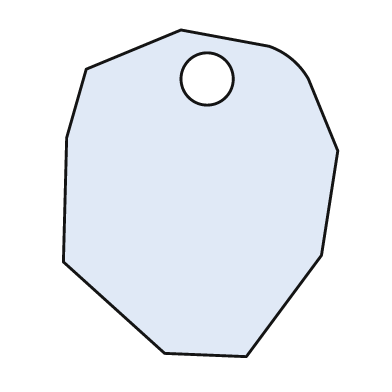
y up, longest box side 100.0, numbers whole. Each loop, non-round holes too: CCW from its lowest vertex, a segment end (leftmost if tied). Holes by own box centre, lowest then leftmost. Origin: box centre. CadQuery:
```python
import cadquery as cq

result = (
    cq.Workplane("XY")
    .moveTo(14.0, -50.0)
    .lineTo(37.0, -19.0)
    .lineTo(42.0, 13.0)
    .lineTo(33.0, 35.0)
    .threePointArc((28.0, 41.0), (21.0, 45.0))
    .lineTo(-6.0, 50.0)
    .lineTo(-35.0, 38.0)
    .lineTo(-41.0, 17.0)
    .lineTo(-42.0, -21.0)
    .lineTo(-11.0, -49.0)
    .close()
    .moveTo(2.0, 35.0)
    .circle(8.0)
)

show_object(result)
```